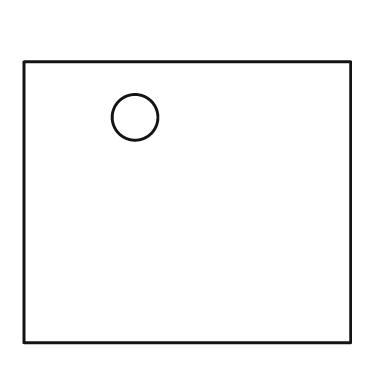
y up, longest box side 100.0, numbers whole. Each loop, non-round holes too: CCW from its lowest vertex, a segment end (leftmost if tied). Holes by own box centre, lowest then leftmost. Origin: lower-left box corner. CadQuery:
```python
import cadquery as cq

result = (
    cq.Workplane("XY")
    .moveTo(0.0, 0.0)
    .lineTo(100.0, 0.0)
    .lineTo(100.0, 86.0)
    .lineTo(0.0, 86.0)
    .close()
    .moveTo(34.0, 69.0)
    .circle(7.0)
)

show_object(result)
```